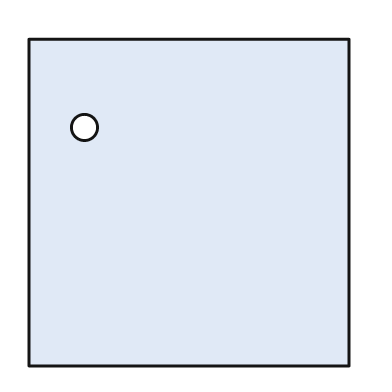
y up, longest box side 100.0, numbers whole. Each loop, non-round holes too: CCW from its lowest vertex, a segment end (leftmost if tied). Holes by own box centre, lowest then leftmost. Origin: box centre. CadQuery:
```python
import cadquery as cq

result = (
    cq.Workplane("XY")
    .moveTo(-49.0, -50.0)
    .lineTo(49.0, -50.0)
    .lineTo(49.0, 50.0)
    .lineTo(-49.0, 50.0)
    .close()
    .moveTo(-32.0, 23.0)
    .circle(4.0)
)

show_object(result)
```